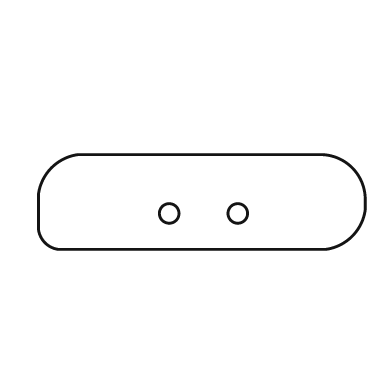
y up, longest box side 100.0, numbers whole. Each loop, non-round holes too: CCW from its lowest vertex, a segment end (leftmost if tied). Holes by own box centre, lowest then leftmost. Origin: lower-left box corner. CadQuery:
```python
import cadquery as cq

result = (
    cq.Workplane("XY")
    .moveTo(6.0, 0.0)
    .lineTo(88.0, 0.0)
    .threePointArc((96.0, 4.0), (100.0, 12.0))
    .lineTo(100.0, 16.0)
    .threePointArc((96.0, 25.0), (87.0, 29.0))
    .lineTo(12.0, 29.0)
    .threePointArc((4.0, 25.0), (0.0, 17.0))
    .lineTo(0.0, 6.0)
    .threePointArc((2.0, 2.0), (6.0, 0.0))
    .close()
    .moveTo(40.0, 11.0)
    .circle(3.0)
    .moveTo(61.0, 11.0)
    .circle(3.0)
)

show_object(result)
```